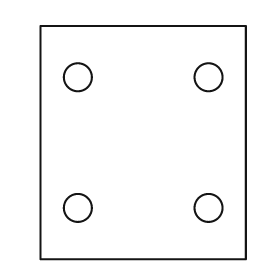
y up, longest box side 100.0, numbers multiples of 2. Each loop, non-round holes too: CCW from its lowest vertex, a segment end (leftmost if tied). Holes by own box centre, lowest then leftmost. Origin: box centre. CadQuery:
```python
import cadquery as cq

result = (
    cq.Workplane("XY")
    .moveTo(-44.0, -50.0)
    .lineTo(44.0, -50.0)
    .lineTo(44.0, 50.0)
    .lineTo(-44.0, 50.0)
    .close()
    .moveTo(-28.0, -28.0)
    .circle(6.0)
    .moveTo(28.0, -28.0)
    .circle(6.0)
    .moveTo(-28.0, 28.0)
    .circle(6.0)
    .moveTo(28.0, 28.0)
    .circle(6.0)
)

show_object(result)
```